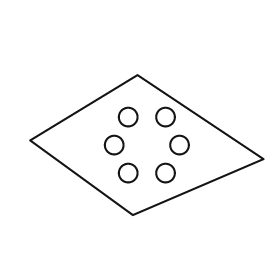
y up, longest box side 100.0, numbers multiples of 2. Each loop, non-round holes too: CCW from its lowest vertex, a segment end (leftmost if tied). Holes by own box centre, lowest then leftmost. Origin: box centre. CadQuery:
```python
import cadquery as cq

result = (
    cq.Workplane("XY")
    .moveTo(-6.0, -30.0)
    .lineTo(50.0, -6.0)
    .lineTo(-4.0, 30.0)
    .lineTo(-50.0, 2.0)
    .close()
    .moveTo(-8.0, -12.0)
    .circle(4.0)
    .moveTo(8.0, -12.0)
    .circle(4.0)
    .moveTo(-14.0, 0.0)
    .circle(4.0)
    .moveTo(14.0, 0.0)
    .circle(4.0)
    .moveTo(-8.0, 12.0)
    .circle(4.0)
    .moveTo(8.0, 12.0)
    .circle(4.0)
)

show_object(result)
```